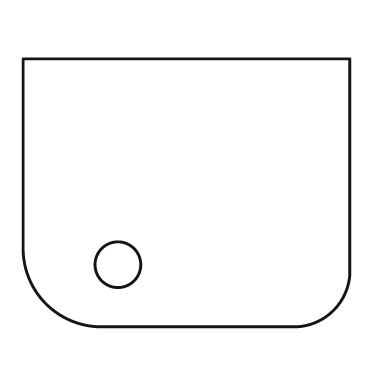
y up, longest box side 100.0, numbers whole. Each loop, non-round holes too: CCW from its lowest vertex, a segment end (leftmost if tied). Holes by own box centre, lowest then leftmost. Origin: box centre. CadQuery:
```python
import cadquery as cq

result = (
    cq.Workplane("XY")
    .moveTo(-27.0, -41.0)
    .lineTo(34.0, -41.0)
    .threePointArc((45.0, -36.0), (50.0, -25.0))
    .lineTo(50.0, 41.0)
    .lineTo(-50.0, 41.0)
    .lineTo(-50.0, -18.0)
    .threePointArc((-43.0, -34.0), (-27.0, -41.0))
    .close()
    .moveTo(-21.0, -22.0)
    .circle(7.0)
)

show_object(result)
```